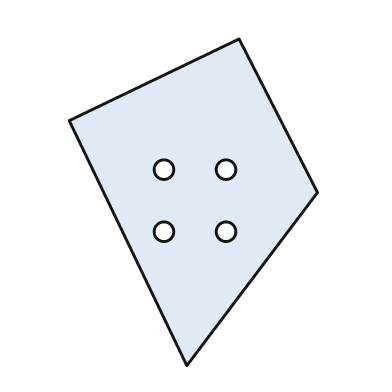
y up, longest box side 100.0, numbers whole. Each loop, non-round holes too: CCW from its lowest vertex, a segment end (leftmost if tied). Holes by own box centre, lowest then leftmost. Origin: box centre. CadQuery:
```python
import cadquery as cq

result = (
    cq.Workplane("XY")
    .moveTo(-2.0, -50.0)
    .lineTo(38.0, 3.0)
    .lineTo(14.0, 50.0)
    .lineTo(-38.0, 25.0)
    .close()
    .moveTo(-9.0, -9.0)
    .circle(3.0)
    .moveTo(10.0, -9.0)
    .circle(3.0)
    .moveTo(-9.0, 10.0)
    .circle(3.0)
    .moveTo(10.0, 10.0)
    .circle(3.0)
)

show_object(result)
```